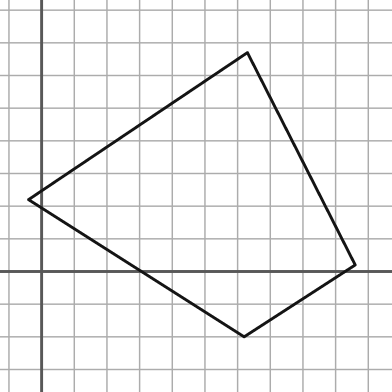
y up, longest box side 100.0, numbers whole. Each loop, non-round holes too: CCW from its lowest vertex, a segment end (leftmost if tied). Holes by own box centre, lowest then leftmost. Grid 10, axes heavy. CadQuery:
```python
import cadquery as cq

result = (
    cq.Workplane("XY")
    .moveTo(62.0, -20.0)
    .lineTo(96.0, 2.0)
    .lineTo(63.0, 67.0)
    .lineTo(-4.0, 22.0)
    .close()
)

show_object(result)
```